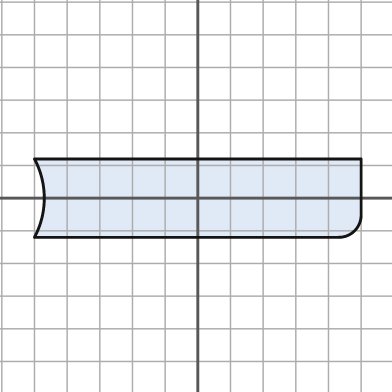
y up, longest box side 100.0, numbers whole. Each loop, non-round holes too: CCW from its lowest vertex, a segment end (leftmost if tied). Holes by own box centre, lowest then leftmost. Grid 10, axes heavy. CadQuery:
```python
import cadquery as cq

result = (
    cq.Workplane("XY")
    .moveTo(-50.0, -12.0)
    .lineTo(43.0, -12.0)
    .threePointArc((48.0, -10.0), (50.0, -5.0))
    .lineTo(50.0, 12.0)
    .lineTo(-50.0, 12.0)
    .threePointArc((-47.0, 0.0), (-50.0, -12.0))
    .close()
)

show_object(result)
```